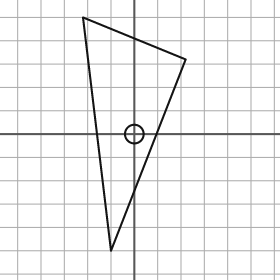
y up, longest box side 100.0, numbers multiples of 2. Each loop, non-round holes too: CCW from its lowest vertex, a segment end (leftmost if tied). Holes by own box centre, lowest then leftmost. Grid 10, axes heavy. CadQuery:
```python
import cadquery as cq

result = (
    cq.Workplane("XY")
    .moveTo(-10.0, -50.0)
    .lineTo(22.0, 32.0)
    .lineTo(-22.0, 50.0)
    .close()
    .moveTo(0.0, 0.0)
    .circle(4.0)
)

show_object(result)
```